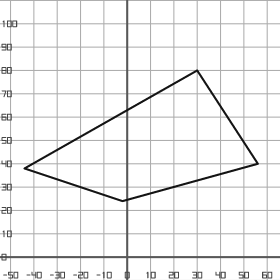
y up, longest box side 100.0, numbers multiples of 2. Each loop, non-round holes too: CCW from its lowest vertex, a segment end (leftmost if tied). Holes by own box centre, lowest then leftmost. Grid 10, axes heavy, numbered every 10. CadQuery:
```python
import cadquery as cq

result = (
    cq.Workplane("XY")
    .moveTo(-2.0, 24.0)
    .lineTo(56.0, 40.0)
    .lineTo(30.0, 80.0)
    .lineTo(-44.0, 38.0)
    .close()
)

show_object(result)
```